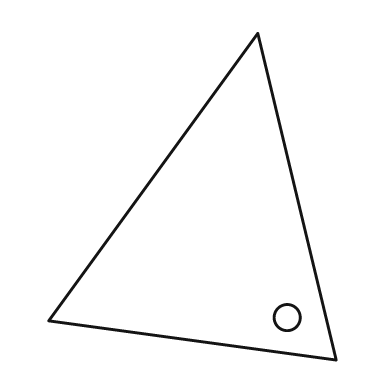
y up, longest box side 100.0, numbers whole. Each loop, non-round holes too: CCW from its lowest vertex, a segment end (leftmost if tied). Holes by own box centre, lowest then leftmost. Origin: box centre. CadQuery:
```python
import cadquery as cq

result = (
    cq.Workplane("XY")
    .moveTo(44.0, -50.0)
    .lineTo(20.0, 50.0)
    .lineTo(-44.0, -38.0)
    .close()
    .moveTo(29.0, -37.0)
    .circle(4.0)
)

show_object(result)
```